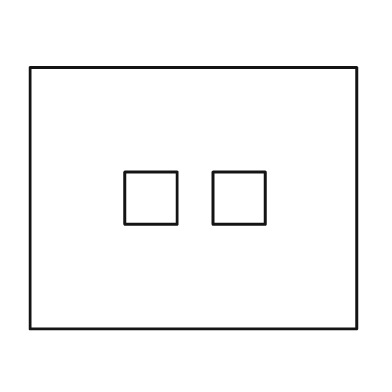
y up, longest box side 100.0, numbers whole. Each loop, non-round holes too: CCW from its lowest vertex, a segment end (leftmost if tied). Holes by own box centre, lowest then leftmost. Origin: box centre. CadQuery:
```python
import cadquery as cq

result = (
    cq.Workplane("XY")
    .moveTo(-50.0, -40.0)
    .lineTo(50.0, -40.0)
    .lineTo(50.0, 40.0)
    .lineTo(-50.0, 40.0)
    .close()
    .moveTo(-21.0, -8.0)
    .lineTo(-5.0, -8.0)
    .lineTo(-5.0, 8.0)
    .lineTo(-21.0, 8.0)
    .close()
    .moveTo(6.0, -8.0)
    .lineTo(22.0, -8.0)
    .lineTo(22.0, 8.0)
    .lineTo(6.0, 8.0)
    .close()
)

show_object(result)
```